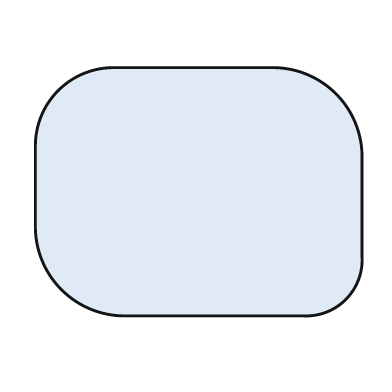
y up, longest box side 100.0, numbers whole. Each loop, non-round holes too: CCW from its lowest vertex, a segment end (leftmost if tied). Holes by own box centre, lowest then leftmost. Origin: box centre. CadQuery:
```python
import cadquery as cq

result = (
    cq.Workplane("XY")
    .moveTo(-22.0, -38.0)
    .lineTo(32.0, -38.0)
    .threePointArc((45.0, -33.0), (50.0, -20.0))
    .lineTo(50.0, 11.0)
    .threePointArc((42.0, 30.0), (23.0, 38.0))
    .lineTo(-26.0, 38.0)
    .threePointArc((-43.0, 31.0), (-50.0, 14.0))
    .lineTo(-50.0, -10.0)
    .threePointArc((-42.0, -30.0), (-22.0, -38.0))
    .close()
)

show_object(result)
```